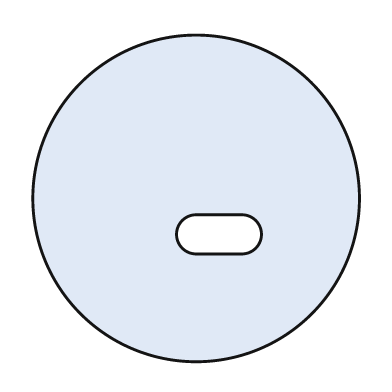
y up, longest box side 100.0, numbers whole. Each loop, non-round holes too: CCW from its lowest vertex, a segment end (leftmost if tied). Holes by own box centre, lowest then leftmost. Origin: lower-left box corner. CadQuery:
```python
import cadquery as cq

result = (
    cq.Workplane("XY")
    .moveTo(50.0, 50.0)
    .circle(50.0)
    .moveTo(50.0, 33.0)
    .lineTo(64.0, 33.0)
    .threePointArc((70.0, 39.0), (64.0, 45.0))
    .lineTo(50.0, 45.0)
    .threePointArc((44.0, 39.0), (50.0, 33.0))
    .close()
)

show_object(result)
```